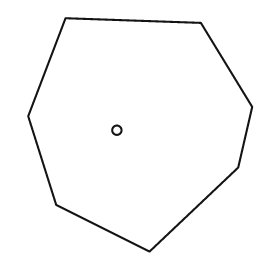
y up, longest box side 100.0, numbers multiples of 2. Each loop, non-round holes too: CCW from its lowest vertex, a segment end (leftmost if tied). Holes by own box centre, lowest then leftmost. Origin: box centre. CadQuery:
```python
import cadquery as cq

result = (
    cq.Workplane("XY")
    .moveTo(4.0, -50.0)
    .lineTo(42.0, -14.0)
    .lineTo(48.0, 12.0)
    .lineTo(26.0, 48.0)
    .lineTo(-32.0, 50.0)
    .lineTo(-48.0, 8.0)
    .lineTo(-36.0, -30.0)
    .close()
    .moveTo(-10.0, 2.0)
    .circle(2.0)
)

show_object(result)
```